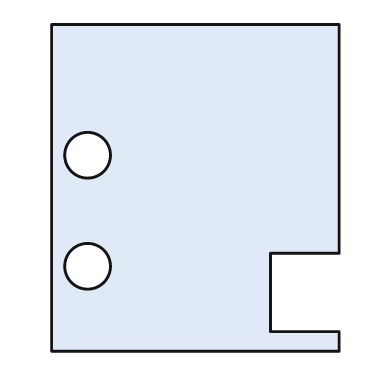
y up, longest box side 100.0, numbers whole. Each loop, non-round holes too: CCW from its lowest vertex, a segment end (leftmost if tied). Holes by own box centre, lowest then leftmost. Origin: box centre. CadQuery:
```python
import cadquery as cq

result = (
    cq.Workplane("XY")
    .moveTo(-44.0, -50.0)
    .lineTo(44.0, -50.0)
    .lineTo(44.0, -44.0)
    .lineTo(23.0, -44.0)
    .lineTo(23.0, -20.0)
    .lineTo(44.0, -20.0)
    .lineTo(44.0, 50.0)
    .lineTo(-44.0, 50.0)
    .close()
    .moveTo(-33.0, -24.0)
    .circle(7.0)
    .moveTo(-33.0, 10.0)
    .circle(7.0)
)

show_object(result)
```